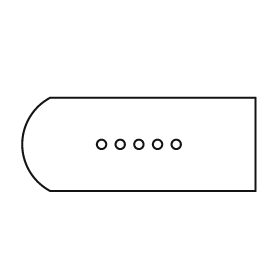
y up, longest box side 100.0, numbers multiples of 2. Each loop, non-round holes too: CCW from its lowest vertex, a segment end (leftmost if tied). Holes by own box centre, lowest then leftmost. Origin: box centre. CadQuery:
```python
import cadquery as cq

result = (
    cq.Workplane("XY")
    .moveTo(-38.0, -20.0)
    .lineTo(50.0, -20.0)
    .lineTo(50.0, 20.0)
    .lineTo(-38.0, 20.0)
    .threePointArc((-50.0, 0.0), (-38.0, -20.0))
    .close()
    .moveTo(-16.0, 0.0)
    .circle(2.0)
    .moveTo(-8.0, 0.0)
    .circle(2.0)
    .moveTo(0.0, 0.0)
    .circle(2.0)
    .moveTo(8.0, 0.0)
    .circle(2.0)
    .moveTo(16.0, 0.0)
    .circle(2.0)
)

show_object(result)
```